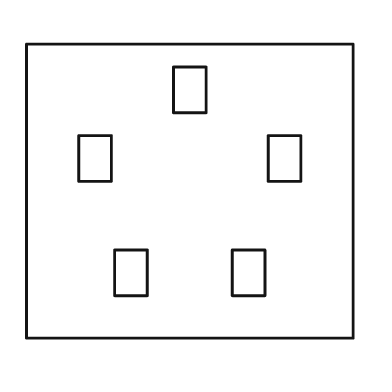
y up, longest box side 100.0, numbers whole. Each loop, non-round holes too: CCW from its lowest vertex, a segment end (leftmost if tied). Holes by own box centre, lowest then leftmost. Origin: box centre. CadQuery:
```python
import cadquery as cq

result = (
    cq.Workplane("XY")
    .moveTo(-50.0, -45.0)
    .lineTo(50.0, -45.0)
    .lineTo(50.0, 45.0)
    .lineTo(-50.0, 45.0)
    .close()
    .moveTo(-23.0, -32.0)
    .lineTo(-13.0, -32.0)
    .lineTo(-13.0, -18.0)
    .lineTo(-23.0, -18.0)
    .close()
    .moveTo(13.0, -32.0)
    .lineTo(23.0, -32.0)
    .lineTo(23.0, -18.0)
    .lineTo(13.0, -18.0)
    .close()
    .moveTo(-34.0, 3.0)
    .lineTo(-24.0, 3.0)
    .lineTo(-24.0, 17.0)
    .lineTo(-34.0, 17.0)
    .close()
    .moveTo(24.0, 3.0)
    .lineTo(34.0, 3.0)
    .lineTo(34.0, 17.0)
    .lineTo(24.0, 17.0)
    .close()
    .moveTo(-5.0, 24.0)
    .lineTo(5.0, 24.0)
    .lineTo(5.0, 38.0)
    .lineTo(-5.0, 38.0)
    .close()
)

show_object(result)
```